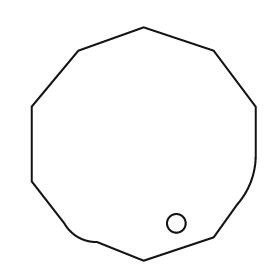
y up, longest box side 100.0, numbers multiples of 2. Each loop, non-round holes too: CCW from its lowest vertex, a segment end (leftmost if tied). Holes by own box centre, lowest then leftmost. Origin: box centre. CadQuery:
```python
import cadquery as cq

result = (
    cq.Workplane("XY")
    .moveTo(0.0, -50.0)
    .lineTo(30.0, -40.0)
    .lineTo(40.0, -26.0)
    .threePointArc((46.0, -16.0), (48.0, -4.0))
    .lineTo(48.0, 16.0)
    .lineTo(30.0, 40.0)
    .lineTo(0.0, 50.0)
    .lineTo(-28.0, 40.0)
    .lineTo(-48.0, 16.0)
    .lineTo(-48.0, -16.0)
    .lineTo(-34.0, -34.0)
    .threePointArc((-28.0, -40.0), (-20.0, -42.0))
    .close()
    .moveTo(14.0, -34.0)
    .circle(4.0)
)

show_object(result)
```